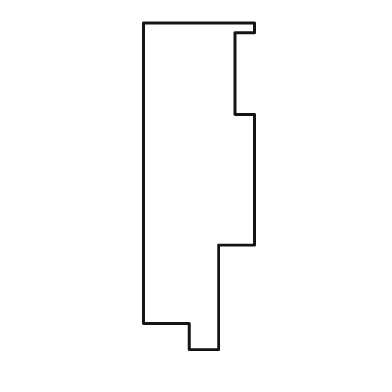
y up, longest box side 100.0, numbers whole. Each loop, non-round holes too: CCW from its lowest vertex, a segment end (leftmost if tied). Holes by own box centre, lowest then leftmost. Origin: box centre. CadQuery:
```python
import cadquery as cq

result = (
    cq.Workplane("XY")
    .moveTo(-3.0, -50.0)
    .lineTo(6.0, -50.0)
    .lineTo(6.0, -18.0)
    .lineTo(17.0, -18.0)
    .lineTo(17.0, 22.0)
    .lineTo(11.0, 22.0)
    .lineTo(11.0, 47.0)
    .lineTo(17.0, 47.0)
    .lineTo(17.0, 50.0)
    .lineTo(-17.0, 50.0)
    .lineTo(-17.0, -42.0)
    .lineTo(-3.0, -42.0)
    .close()
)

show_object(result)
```